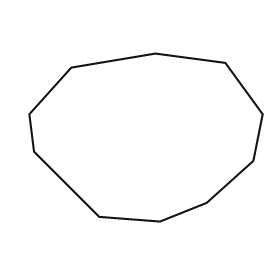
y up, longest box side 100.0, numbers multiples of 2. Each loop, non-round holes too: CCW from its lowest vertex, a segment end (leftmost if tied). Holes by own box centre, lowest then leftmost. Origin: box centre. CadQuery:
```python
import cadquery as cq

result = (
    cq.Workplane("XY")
    .moveTo(6.0, -36.0)
    .lineTo(26.0, -28.0)
    .lineTo(46.0, -10.0)
    .lineTo(50.0, 10.0)
    .lineTo(34.0, 32.0)
    .lineTo(4.0, 36.0)
    .lineTo(-32.0, 30.0)
    .lineTo(-50.0, 10.0)
    .lineTo(-48.0, -6.0)
    .lineTo(-20.0, -34.0)
    .close()
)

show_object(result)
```